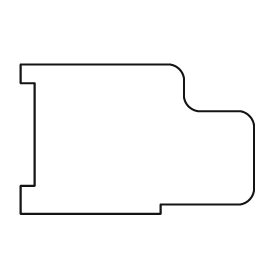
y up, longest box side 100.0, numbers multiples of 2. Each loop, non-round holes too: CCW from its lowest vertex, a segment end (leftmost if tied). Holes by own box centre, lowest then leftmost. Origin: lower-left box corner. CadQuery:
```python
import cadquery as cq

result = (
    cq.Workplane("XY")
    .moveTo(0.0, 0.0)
    .lineTo(60.0, 0.0)
    .lineTo(60.0, 4.0)
    .lineTo(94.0, 4.0)
    .threePointArc((98.0, 6.0), (100.0, 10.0))
    .lineTo(100.0, 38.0)
    .threePointArc((98.0, 42.0), (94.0, 44.0))
    .lineTo(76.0, 44.0)
    .threePointArc((72.0, 46.0), (70.0, 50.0))
    .lineTo(70.0, 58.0)
    .threePointArc((68.0, 62.0), (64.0, 64.0))
    .lineTo(0.0, 64.0)
    .lineTo(0.0, 56.0)
    .lineTo(6.0, 56.0)
    .lineTo(6.0, 12.0)
    .lineTo(0.0, 12.0)
    .close()
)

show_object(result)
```